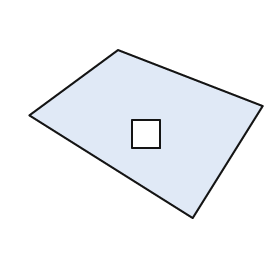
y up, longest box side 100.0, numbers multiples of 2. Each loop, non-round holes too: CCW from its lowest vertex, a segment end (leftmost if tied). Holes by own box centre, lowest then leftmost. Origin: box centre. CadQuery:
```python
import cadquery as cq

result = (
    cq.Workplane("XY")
    .moveTo(20.0, -36.0)
    .lineTo(50.0, 12.0)
    .lineTo(-12.0, 36.0)
    .lineTo(-50.0, 8.0)
    .close()
    .moveTo(-6.0, -6.0)
    .lineTo(6.0, -6.0)
    .lineTo(6.0, 6.0)
    .lineTo(-6.0, 6.0)
    .close()
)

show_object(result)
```